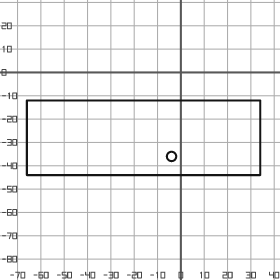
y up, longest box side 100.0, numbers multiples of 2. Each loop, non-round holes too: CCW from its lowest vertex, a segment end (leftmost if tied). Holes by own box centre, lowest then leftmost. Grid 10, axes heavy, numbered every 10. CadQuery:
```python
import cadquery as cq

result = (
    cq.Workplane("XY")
    .moveTo(-66.0, -44.0)
    .lineTo(34.0, -44.0)
    .lineTo(34.0, -12.0)
    .lineTo(-66.0, -12.0)
    .close()
    .moveTo(-4.0, -36.0)
    .circle(2.0)
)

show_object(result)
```